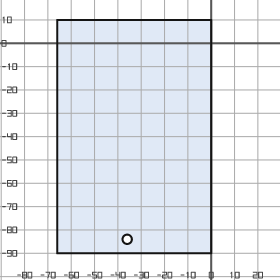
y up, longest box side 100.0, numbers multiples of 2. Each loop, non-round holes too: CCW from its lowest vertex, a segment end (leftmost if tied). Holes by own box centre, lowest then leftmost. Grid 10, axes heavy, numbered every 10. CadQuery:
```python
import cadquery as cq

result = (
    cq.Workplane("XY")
    .moveTo(-66.0, -90.0)
    .lineTo(0.0, -90.0)
    .lineTo(0.0, 10.0)
    .lineTo(-66.0, 10.0)
    .close()
    .moveTo(-36.0, -84.0)
    .circle(2.0)
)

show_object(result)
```